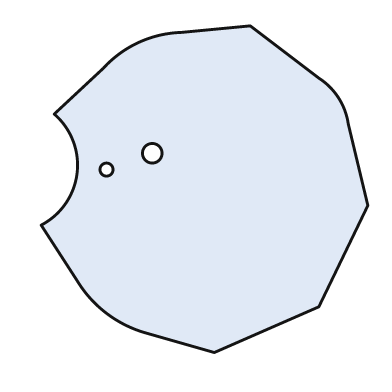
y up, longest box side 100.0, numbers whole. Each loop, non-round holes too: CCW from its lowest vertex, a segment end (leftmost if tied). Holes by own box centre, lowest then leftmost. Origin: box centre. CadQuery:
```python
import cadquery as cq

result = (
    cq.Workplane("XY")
    .moveTo(3.0, -50.0)
    .lineTo(35.0, -36.0)
    .lineTo(50.0, -5.0)
    .lineTo(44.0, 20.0)
    .threePointArc((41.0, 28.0), (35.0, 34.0))
    .lineTo(14.0, 50.0)
    .lineTo(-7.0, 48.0)
    .threePointArc((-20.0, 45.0), (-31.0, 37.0))
    .lineTo(-46.0, 23.0)
    .threePointArc((-39.0, 5.0), (-50.0, -11.0))
    .lineTo(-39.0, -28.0)
    .threePointArc((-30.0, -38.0), (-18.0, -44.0))
    .close()
    .moveTo(-30.0, 6.0)
    .circle(2.0)
    .moveTo(-16.0, 11.0)
    .circle(3.0)
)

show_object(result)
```